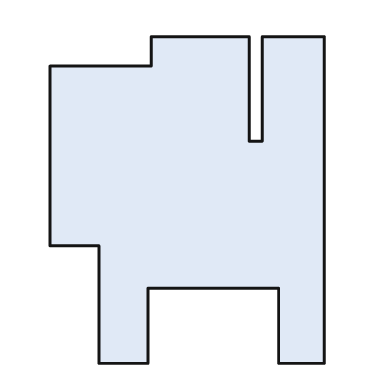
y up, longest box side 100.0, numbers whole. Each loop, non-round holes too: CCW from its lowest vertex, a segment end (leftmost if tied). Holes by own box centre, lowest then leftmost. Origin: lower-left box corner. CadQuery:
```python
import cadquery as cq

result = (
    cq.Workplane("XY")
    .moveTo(15.0, 0.0)
    .lineTo(30.0, 0.0)
    .lineTo(30.0, 23.0)
    .lineTo(70.0, 23.0)
    .lineTo(70.0, 0.0)
    .lineTo(84.0, 0.0)
    .lineTo(84.0, 100.0)
    .lineTo(65.0, 100.0)
    .lineTo(65.0, 68.0)
    .lineTo(61.0, 68.0)
    .lineTo(61.0, 100.0)
    .lineTo(31.0, 100.0)
    .lineTo(31.0, 91.0)
    .lineTo(0.0, 91.0)
    .lineTo(0.0, 36.0)
    .lineTo(15.0, 36.0)
    .close()
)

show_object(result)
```